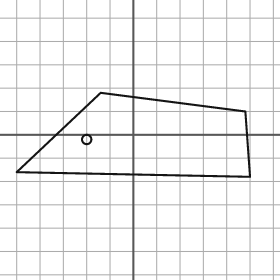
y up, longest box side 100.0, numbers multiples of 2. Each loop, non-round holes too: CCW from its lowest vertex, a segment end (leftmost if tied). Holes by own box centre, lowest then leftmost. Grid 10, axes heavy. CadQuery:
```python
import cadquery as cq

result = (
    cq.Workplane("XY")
    .moveTo(50.0, -18.0)
    .lineTo(48.0, 10.0)
    .lineTo(-14.0, 18.0)
    .lineTo(-50.0, -16.0)
    .close()
    .moveTo(-20.0, -2.0)
    .circle(2.0)
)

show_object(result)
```